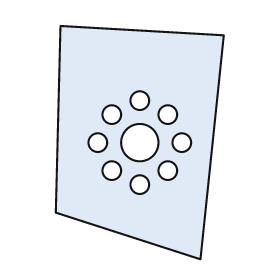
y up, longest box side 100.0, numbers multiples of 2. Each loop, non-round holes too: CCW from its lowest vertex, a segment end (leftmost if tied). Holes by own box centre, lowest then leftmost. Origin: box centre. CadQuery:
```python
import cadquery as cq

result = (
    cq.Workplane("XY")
    .moveTo(26.0, -50.0)
    .lineTo(36.0, 46.0)
    .lineTo(-34.0, 50.0)
    .lineTo(-36.0, -30.0)
    .close()
    .moveTo(0.0, -18.0)
    .circle(4.0)
    .moveTo(-12.0, -12.0)
    .circle(4.0)
    .moveTo(12.0, -12.0)
    .circle(4.0)
    .moveTo(-18.0, 0.0)
    .circle(4.0)
    .moveTo(0.0, 0.0)
    .circle(8.0)
    .moveTo(18.0, 0.0)
    .circle(4.0)
    .moveTo(-12.0, 12.0)
    .circle(4.0)
    .moveTo(12.0, 12.0)
    .circle(4.0)
    .moveTo(0.0, 18.0)
    .circle(4.0)
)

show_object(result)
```